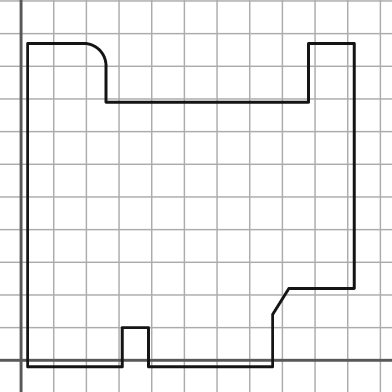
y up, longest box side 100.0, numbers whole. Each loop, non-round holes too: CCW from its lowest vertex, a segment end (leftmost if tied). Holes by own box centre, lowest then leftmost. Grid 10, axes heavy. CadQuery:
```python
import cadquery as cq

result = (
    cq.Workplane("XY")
    .moveTo(2.0, -2.0)
    .lineTo(31.0, -2.0)
    .lineTo(31.0, 10.0)
    .lineTo(39.0, 10.0)
    .lineTo(39.0, -2.0)
    .lineTo(77.0, -2.0)
    .lineTo(77.0, 14.0)
    .lineTo(82.0, 22.0)
    .lineTo(102.0, 22.0)
    .lineTo(102.0, 97.0)
    .lineTo(88.0, 97.0)
    .lineTo(88.0, 79.0)
    .lineTo(26.0, 79.0)
    .lineTo(26.0, 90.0)
    .threePointArc((24.0, 95.0), (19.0, 97.0))
    .lineTo(2.0, 97.0)
    .close()
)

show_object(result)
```